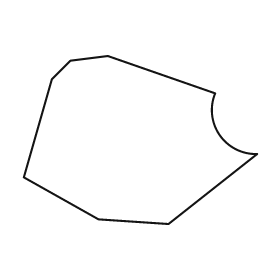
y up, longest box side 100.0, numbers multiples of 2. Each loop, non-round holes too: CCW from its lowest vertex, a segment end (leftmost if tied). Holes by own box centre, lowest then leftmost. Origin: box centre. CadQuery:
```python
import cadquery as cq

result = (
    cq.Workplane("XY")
    .moveTo(12.0, -36.0)
    .lineTo(50.0, -6.0)
    .threePointArc((34.0, 2.0), (32.0, 20.0))
    .lineTo(-14.0, 36.0)
    .lineTo(-30.0, 34.0)
    .lineTo(-38.0, 26.0)
    .lineTo(-50.0, -16.0)
    .lineTo(-18.0, -34.0)
    .close()
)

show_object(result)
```